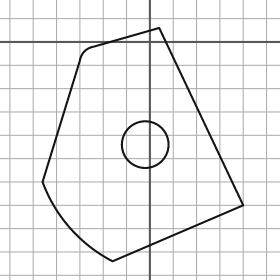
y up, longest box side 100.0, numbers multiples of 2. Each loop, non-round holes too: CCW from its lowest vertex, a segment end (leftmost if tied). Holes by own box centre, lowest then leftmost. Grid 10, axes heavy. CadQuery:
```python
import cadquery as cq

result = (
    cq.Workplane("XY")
    .moveTo(-16.0, -94.0)
    .lineTo(40.0, -70.0)
    .lineTo(4.0, 6.0)
    .lineTo(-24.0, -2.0)
    .threePointArc((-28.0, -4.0), (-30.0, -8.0))
    .lineTo(-46.0, -60.0)
    .threePointArc((-34.0, -80.0), (-16.0, -94.0))
    .close()
    .moveTo(-2.0, -44.0)
    .circle(10.0)
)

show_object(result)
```